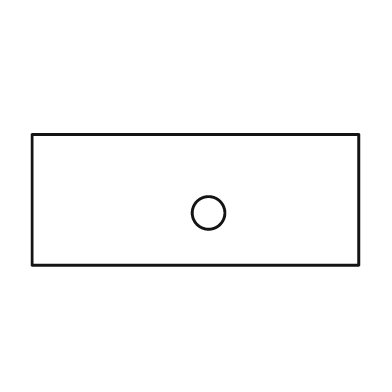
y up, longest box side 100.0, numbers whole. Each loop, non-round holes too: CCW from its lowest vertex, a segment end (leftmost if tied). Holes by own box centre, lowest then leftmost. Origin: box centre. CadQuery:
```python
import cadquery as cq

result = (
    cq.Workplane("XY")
    .moveTo(-50.0, -20.0)
    .lineTo(50.0, -20.0)
    .lineTo(50.0, 20.0)
    .lineTo(-50.0, 20.0)
    .close()
    .moveTo(4.0, -4.0)
    .circle(5.0)
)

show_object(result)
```